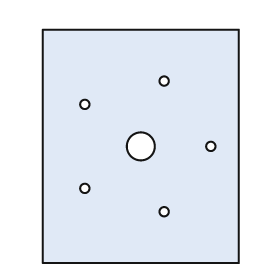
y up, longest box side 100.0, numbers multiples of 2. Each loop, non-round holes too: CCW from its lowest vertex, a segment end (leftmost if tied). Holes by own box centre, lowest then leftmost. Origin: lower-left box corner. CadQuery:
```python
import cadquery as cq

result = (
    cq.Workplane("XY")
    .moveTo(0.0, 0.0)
    .lineTo(84.0, 0.0)
    .lineTo(84.0, 100.0)
    .lineTo(0.0, 100.0)
    .close()
    .moveTo(52.0, 22.0)
    .circle(2.0)
    .moveTo(18.0, 32.0)
    .circle(2.0)
    .moveTo(42.0, 50.0)
    .circle(6.0)
    .moveTo(72.0, 50.0)
    .circle(2.0)
    .moveTo(18.0, 68.0)
    .circle(2.0)
    .moveTo(52.0, 78.0)
    .circle(2.0)
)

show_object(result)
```